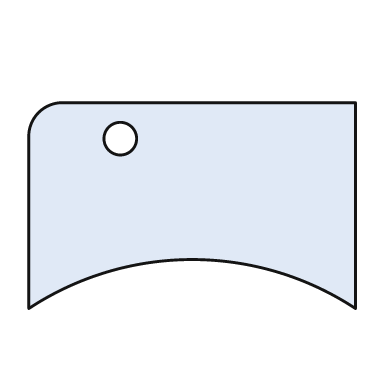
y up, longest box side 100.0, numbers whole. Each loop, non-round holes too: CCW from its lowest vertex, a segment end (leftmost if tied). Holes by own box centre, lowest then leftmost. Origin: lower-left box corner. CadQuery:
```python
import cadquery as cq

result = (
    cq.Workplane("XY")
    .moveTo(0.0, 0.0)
    .threePointArc((50.0, 15.0), (100.0, 0.0))
    .lineTo(100.0, 63.0)
    .lineTo(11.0, 63.0)
    .threePointArc((3.0, 60.0), (0.0, 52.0))
    .close()
    .moveTo(28.0, 52.0)
    .circle(5.0)
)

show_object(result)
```